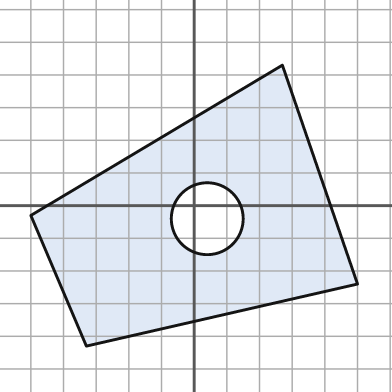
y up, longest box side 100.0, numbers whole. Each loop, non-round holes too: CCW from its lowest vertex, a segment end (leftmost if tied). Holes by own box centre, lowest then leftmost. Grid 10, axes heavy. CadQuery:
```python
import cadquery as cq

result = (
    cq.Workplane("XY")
    .moveTo(-33.0, -43.0)
    .lineTo(50.0, -24.0)
    .lineTo(27.0, 43.0)
    .lineTo(-50.0, -3.0)
    .close()
    .moveTo(4.0, -4.0)
    .circle(11.0)
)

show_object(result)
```